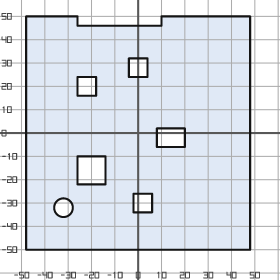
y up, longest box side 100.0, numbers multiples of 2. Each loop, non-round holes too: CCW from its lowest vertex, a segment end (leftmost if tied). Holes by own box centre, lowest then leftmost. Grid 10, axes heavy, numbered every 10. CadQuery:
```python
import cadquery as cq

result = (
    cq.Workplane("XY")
    .moveTo(-48.0, -50.0)
    .lineTo(48.0, -50.0)
    .lineTo(48.0, 50.0)
    .lineTo(10.0, 50.0)
    .lineTo(10.0, 46.0)
    .lineTo(-26.0, 46.0)
    .lineTo(-26.0, 50.0)
    .lineTo(-48.0, 50.0)
    .close()
    .moveTo(-32.0, -32.0)
    .circle(4.0)
    .moveTo(-2.0, -34.0)
    .lineTo(6.0, -34.0)
    .lineTo(6.0, -26.0)
    .lineTo(-2.0, -26.0)
    .close()
    .moveTo(-26.0, -22.0)
    .lineTo(-14.0, -22.0)
    .lineTo(-14.0, -10.0)
    .lineTo(-26.0, -10.0)
    .close()
    .moveTo(8.0, -6.0)
    .lineTo(20.0, -6.0)
    .lineTo(20.0, 2.0)
    .lineTo(8.0, 2.0)
    .close()
    .moveTo(-26.0, 16.0)
    .lineTo(-18.0, 16.0)
    .lineTo(-18.0, 24.0)
    .lineTo(-26.0, 24.0)
    .close()
    .moveTo(-4.0, 24.0)
    .lineTo(4.0, 24.0)
    .lineTo(4.0, 32.0)
    .lineTo(-4.0, 32.0)
    .close()
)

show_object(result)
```